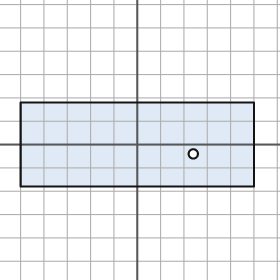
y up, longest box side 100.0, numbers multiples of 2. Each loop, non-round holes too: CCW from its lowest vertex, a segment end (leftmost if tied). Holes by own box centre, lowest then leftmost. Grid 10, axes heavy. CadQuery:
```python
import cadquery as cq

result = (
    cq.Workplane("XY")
    .moveTo(-50.0, -18.0)
    .lineTo(50.0, -18.0)
    .lineTo(50.0, 18.0)
    .lineTo(-50.0, 18.0)
    .close()
    .moveTo(24.0, -4.0)
    .circle(2.0)
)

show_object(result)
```